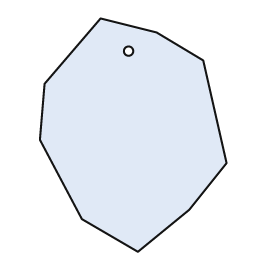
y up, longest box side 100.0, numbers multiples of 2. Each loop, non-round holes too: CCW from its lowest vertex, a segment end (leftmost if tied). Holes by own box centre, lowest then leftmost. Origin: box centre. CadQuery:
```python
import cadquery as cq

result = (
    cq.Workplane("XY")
    .moveTo(2.0, -50.0)
    .lineTo(24.0, -32.0)
    .lineTo(40.0, -12.0)
    .lineTo(30.0, 32.0)
    .lineTo(10.0, 44.0)
    .lineTo(-14.0, 50.0)
    .lineTo(-38.0, 22.0)
    .lineTo(-40.0, -2.0)
    .lineTo(-22.0, -36.0)
    .close()
    .moveTo(-2.0, 36.0)
    .circle(2.0)
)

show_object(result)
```